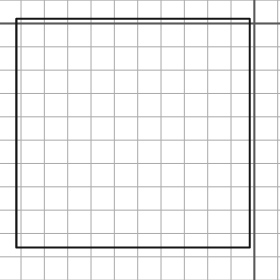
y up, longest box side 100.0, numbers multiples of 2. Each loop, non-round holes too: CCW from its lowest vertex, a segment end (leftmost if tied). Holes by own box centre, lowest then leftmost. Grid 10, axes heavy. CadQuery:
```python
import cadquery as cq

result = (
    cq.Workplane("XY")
    .moveTo(-102.0, -96.0)
    .lineTo(-2.0, -96.0)
    .lineTo(-2.0, 2.0)
    .lineTo(-102.0, 2.0)
    .close()
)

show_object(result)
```